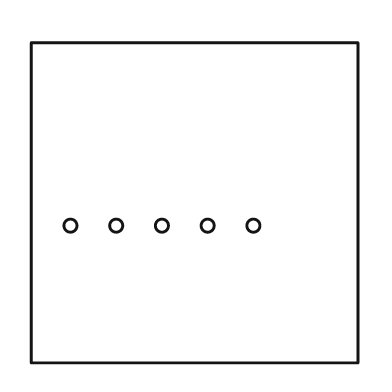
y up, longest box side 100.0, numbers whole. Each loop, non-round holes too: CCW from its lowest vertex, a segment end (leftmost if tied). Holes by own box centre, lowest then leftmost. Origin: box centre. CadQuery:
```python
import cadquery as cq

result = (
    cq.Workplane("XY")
    .moveTo(-50.0, -49.0)
    .lineTo(50.0, -49.0)
    .lineTo(50.0, 49.0)
    .lineTo(-50.0, 49.0)
    .close()
    .moveTo(-38.0, -7.0)
    .circle(2.0)
    .moveTo(-24.0, -7.0)
    .circle(2.0)
    .moveTo(-10.0, -7.0)
    .circle(2.0)
    .moveTo(4.0, -7.0)
    .circle(2.0)
    .moveTo(18.0, -7.0)
    .circle(2.0)
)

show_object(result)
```